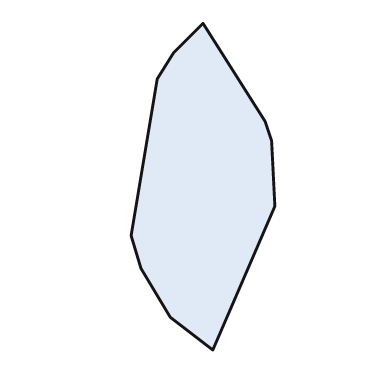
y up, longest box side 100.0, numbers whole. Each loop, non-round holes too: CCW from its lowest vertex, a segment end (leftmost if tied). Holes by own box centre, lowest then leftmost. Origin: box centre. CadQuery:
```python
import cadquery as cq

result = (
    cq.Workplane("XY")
    .moveTo(3.0, -50.0)
    .lineTo(22.0, -6.0)
    .lineTo(21.0, 14.0)
    .lineTo(19.0, 20.0)
    .lineTo(0.0, 50.0)
    .lineTo(-9.0, 41.0)
    .lineTo(-14.0, 33.0)
    .lineTo(-22.0, -15.0)
    .lineTo(-19.0, -25.0)
    .lineTo(-10.0, -40.0)
    .close()
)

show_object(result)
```